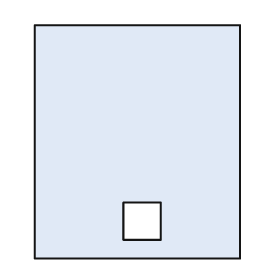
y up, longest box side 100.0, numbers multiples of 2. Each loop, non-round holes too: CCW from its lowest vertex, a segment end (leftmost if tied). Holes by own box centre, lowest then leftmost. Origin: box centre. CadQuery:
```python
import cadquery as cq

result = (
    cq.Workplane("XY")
    .moveTo(-44.0, -50.0)
    .lineTo(44.0, -50.0)
    .lineTo(44.0, 50.0)
    .lineTo(-44.0, 50.0)
    .close()
    .moveTo(-6.0, -42.0)
    .lineTo(10.0, -42.0)
    .lineTo(10.0, -26.0)
    .lineTo(-6.0, -26.0)
    .close()
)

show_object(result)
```